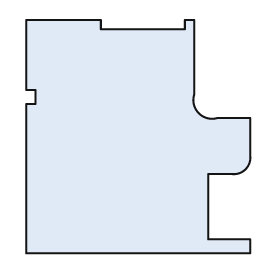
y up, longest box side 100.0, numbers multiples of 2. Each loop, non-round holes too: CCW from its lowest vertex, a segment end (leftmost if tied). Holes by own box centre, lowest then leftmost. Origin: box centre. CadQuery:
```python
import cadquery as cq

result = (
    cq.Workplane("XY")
    .moveTo(-48.0, -50.0)
    .lineTo(48.0, -50.0)
    .lineTo(48.0, -44.0)
    .lineTo(30.0, -44.0)
    .lineTo(30.0, -16.0)
    .lineTo(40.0, -16.0)
    .threePointArc((46.0, -14.0), (48.0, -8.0))
    .lineTo(48.0, 8.0)
    .lineTo(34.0, 8.0)
    .threePointArc((26.0, 10.0), (24.0, 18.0))
    .lineTo(24.0, 50.0)
    .lineTo(20.0, 50.0)
    .lineTo(20.0, 46.0)
    .lineTo(-16.0, 46.0)
    .lineTo(-16.0, 50.0)
    .lineTo(-48.0, 50.0)
    .lineTo(-48.0, 20.0)
    .lineTo(-44.0, 20.0)
    .lineTo(-44.0, 14.0)
    .lineTo(-48.0, 14.0)
    .close()
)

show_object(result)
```